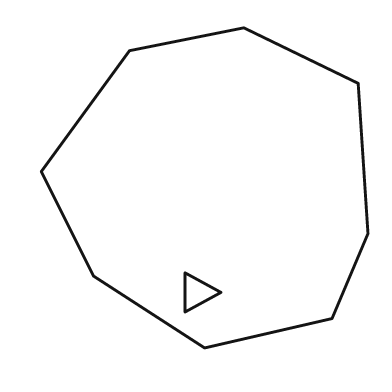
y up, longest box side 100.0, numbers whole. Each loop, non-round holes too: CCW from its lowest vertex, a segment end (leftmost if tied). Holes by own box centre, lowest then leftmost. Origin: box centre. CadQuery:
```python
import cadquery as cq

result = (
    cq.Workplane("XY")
    .moveTo(0.0, -49.0)
    .lineTo(39.0, -40.0)
    .lineTo(50.0, -14.0)
    .lineTo(47.0, 32.0)
    .lineTo(12.0, 49.0)
    .lineTo(-23.0, 42.0)
    .lineTo(-50.0, 5.0)
    .lineTo(-34.0, -27.0)
    .close()
    .moveTo(-6.0, -38.0)
    .lineTo(5.0, -32.0)
    .lineTo(-6.0, -26.0)
    .close()
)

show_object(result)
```